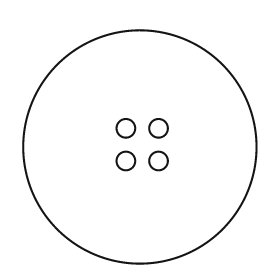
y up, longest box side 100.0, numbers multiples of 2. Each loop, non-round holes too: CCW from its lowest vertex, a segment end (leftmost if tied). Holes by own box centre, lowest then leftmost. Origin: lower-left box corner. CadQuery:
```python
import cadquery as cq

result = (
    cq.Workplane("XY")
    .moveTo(50.0, 50.0)
    .circle(50.0)
    .moveTo(44.0, 44.0)
    .circle(4.0)
    .moveTo(58.0, 44.0)
    .circle(4.0)
    .moveTo(44.0, 58.0)
    .circle(4.0)
    .moveTo(58.0, 58.0)
    .circle(4.0)
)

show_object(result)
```